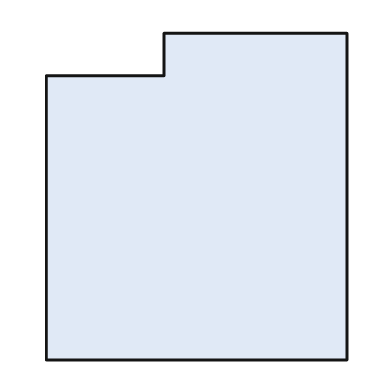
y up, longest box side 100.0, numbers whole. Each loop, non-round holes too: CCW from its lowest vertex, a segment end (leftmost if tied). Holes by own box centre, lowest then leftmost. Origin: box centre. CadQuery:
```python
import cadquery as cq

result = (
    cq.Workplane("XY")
    .moveTo(-46.0, -50.0)
    .lineTo(46.0, -50.0)
    .lineTo(46.0, 50.0)
    .lineTo(-10.0, 50.0)
    .lineTo(-10.0, 37.0)
    .lineTo(-46.0, 37.0)
    .close()
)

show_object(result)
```